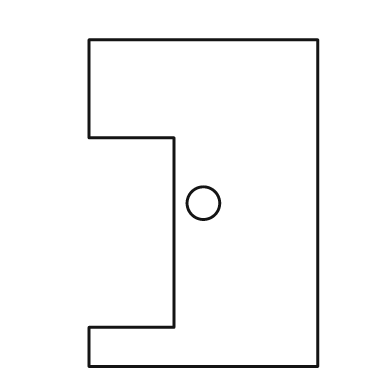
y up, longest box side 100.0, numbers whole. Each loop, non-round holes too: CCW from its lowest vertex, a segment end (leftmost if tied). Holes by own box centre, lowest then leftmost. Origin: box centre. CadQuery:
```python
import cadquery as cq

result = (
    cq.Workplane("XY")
    .moveTo(-35.0, -50.0)
    .lineTo(35.0, -50.0)
    .lineTo(35.0, 50.0)
    .lineTo(-35.0, 50.0)
    .lineTo(-35.0, 20.0)
    .lineTo(-9.0, 20.0)
    .lineTo(-9.0, -38.0)
    .lineTo(-35.0, -38.0)
    .close()
    .moveTo(0.0, 0.0)
    .circle(5.0)
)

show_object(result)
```